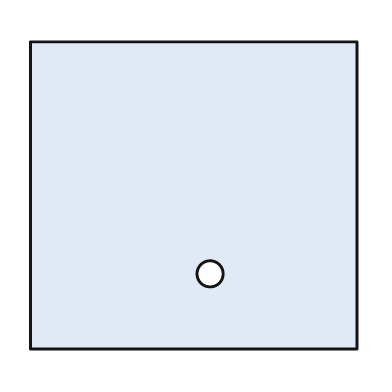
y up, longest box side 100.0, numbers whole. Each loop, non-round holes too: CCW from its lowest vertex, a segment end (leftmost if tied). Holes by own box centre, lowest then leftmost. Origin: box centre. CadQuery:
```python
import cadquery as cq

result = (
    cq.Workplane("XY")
    .moveTo(-50.0, -47.0)
    .lineTo(50.0, -47.0)
    .lineTo(50.0, 47.0)
    .lineTo(-50.0, 47.0)
    .close()
    .moveTo(5.0, -24.0)
    .circle(4.0)
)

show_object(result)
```